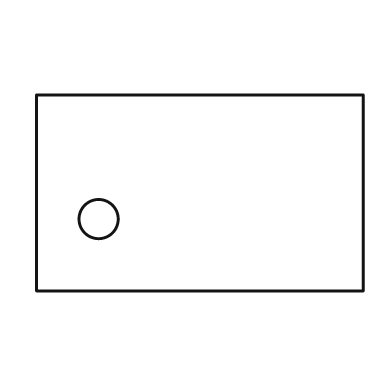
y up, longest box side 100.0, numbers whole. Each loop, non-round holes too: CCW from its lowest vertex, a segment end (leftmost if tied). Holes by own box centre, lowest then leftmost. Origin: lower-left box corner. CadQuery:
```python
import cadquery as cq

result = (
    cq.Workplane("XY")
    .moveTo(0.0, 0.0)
    .lineTo(100.0, 0.0)
    .lineTo(100.0, 60.0)
    .lineTo(0.0, 60.0)
    .close()
    .moveTo(19.0, 22.0)
    .circle(6.0)
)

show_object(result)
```